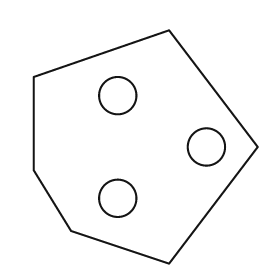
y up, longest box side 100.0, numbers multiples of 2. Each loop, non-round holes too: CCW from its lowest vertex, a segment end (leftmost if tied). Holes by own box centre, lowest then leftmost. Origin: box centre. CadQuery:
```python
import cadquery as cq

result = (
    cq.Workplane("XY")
    .moveTo(10.0, -50.0)
    .lineTo(48.0, 0.0)
    .lineTo(10.0, 50.0)
    .lineTo(-48.0, 30.0)
    .lineTo(-48.0, -10.0)
    .lineTo(-32.0, -36.0)
    .close()
    .moveTo(-12.0, -22.0)
    .circle(8.0)
    .moveTo(26.0, 0.0)
    .circle(8.0)
    .moveTo(-12.0, 22.0)
    .circle(8.0)
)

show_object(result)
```